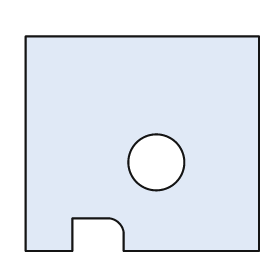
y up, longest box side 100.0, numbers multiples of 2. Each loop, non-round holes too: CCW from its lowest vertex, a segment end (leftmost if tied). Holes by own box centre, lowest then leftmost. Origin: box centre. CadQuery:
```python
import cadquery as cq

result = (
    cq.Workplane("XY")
    .moveTo(-50.0, -46.0)
    .lineTo(-30.0, -46.0)
    .lineTo(-30.0, -32.0)
    .lineTo(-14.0, -32.0)
    .threePointArc((-10.0, -34.0), (-8.0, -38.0))
    .lineTo(-8.0, -46.0)
    .lineTo(50.0, -46.0)
    .lineTo(50.0, 46.0)
    .lineTo(-50.0, 46.0)
    .close()
    .moveTo(6.0, -8.0)
    .circle(12.0)
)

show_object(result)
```